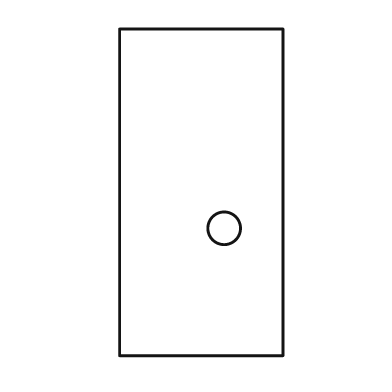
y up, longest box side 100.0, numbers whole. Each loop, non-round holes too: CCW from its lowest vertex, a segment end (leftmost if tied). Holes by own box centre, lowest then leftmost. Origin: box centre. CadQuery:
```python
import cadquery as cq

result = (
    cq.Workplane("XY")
    .moveTo(-25.0, -50.0)
    .lineTo(25.0, -50.0)
    .lineTo(25.0, 50.0)
    .lineTo(-25.0, 50.0)
    .close()
    .moveTo(7.0, -11.0)
    .circle(5.0)
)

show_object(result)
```